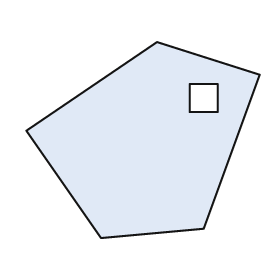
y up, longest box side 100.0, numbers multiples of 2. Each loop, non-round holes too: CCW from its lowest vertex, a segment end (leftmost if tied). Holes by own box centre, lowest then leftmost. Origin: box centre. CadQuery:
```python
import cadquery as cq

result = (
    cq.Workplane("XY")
    .moveTo(-18.0, -42.0)
    .lineTo(26.0, -38.0)
    .lineTo(50.0, 28.0)
    .lineTo(6.0, 42.0)
    .lineTo(-50.0, 4.0)
    .close()
    .moveTo(20.0, 12.0)
    .lineTo(32.0, 12.0)
    .lineTo(32.0, 24.0)
    .lineTo(20.0, 24.0)
    .close()
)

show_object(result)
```